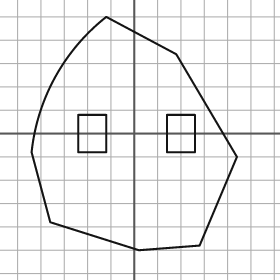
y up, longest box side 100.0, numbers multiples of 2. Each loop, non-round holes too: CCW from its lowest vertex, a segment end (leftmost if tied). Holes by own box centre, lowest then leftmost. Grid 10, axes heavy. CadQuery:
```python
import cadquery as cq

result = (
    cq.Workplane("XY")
    .moveTo(2.0, -50.0)
    .lineTo(28.0, -48.0)
    .lineTo(44.0, -10.0)
    .lineTo(18.0, 34.0)
    .lineTo(-12.0, 50.0)
    .threePointArc((-34.0, 24.0), (-44.0, -8.0))
    .lineTo(-36.0, -38.0)
    .close()
    .moveTo(-24.0, -8.0)
    .lineTo(-12.0, -8.0)
    .lineTo(-12.0, 8.0)
    .lineTo(-24.0, 8.0)
    .close()
    .moveTo(14.0, -8.0)
    .lineTo(26.0, -8.0)
    .lineTo(26.0, 8.0)
    .lineTo(14.0, 8.0)
    .close()
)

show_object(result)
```